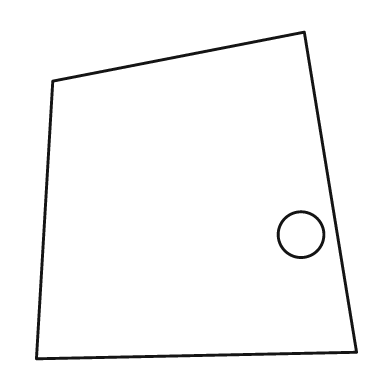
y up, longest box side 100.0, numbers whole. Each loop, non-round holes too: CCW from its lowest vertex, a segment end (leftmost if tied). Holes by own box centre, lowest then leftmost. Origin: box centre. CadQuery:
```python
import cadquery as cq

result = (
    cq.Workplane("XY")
    .moveTo(-49.0, -50.0)
    .lineTo(49.0, -48.0)
    .lineTo(33.0, 50.0)
    .lineTo(-44.0, 35.0)
    .close()
    .moveTo(32.0, -12.0)
    .circle(7.0)
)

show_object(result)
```